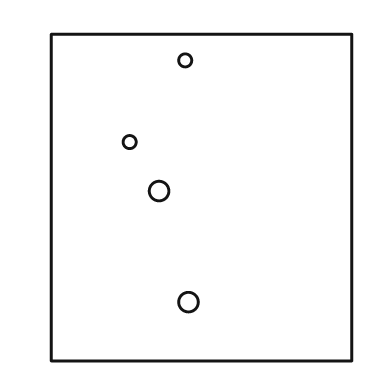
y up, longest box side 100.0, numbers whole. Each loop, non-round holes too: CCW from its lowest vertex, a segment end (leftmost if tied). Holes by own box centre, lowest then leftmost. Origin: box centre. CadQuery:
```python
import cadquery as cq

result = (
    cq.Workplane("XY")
    .moveTo(-46.0, -50.0)
    .lineTo(46.0, -50.0)
    .lineTo(46.0, 50.0)
    .lineTo(-46.0, 50.0)
    .close()
    .moveTo(-4.0, -32.0)
    .circle(3.0)
    .moveTo(-13.0, 2.0)
    .circle(3.0)
    .moveTo(-22.0, 17.0)
    .circle(2.0)
    .moveTo(-5.0, 42.0)
    .circle(2.0)
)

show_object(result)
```